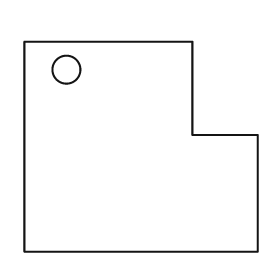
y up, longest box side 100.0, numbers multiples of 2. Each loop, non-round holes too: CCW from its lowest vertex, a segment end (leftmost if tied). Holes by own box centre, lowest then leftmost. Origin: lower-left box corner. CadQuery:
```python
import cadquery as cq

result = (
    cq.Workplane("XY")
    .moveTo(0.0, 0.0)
    .lineTo(100.0, 0.0)
    .lineTo(100.0, 50.0)
    .lineTo(72.0, 50.0)
    .lineTo(72.0, 90.0)
    .lineTo(0.0, 90.0)
    .close()
    .moveTo(18.0, 78.0)
    .circle(6.0)
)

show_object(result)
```